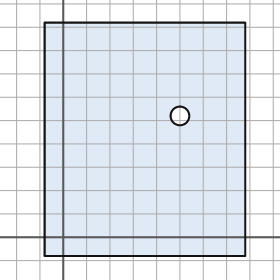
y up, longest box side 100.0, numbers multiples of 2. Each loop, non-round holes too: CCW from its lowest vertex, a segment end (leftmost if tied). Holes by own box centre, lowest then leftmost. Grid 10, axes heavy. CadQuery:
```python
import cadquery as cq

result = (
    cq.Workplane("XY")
    .moveTo(-8.0, -8.0)
    .lineTo(78.0, -8.0)
    .lineTo(78.0, 92.0)
    .lineTo(-8.0, 92.0)
    .close()
    .moveTo(50.0, 52.0)
    .circle(4.0)
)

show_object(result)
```